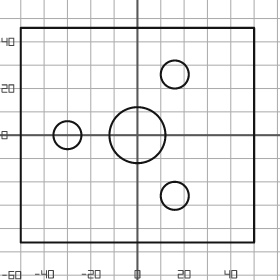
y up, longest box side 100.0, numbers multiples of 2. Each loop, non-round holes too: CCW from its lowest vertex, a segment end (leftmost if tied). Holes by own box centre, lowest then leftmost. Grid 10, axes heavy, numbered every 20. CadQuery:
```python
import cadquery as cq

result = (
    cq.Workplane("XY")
    .moveTo(-50.0, -46.0)
    .lineTo(50.0, -46.0)
    .lineTo(50.0, 46.0)
    .lineTo(-50.0, 46.0)
    .close()
    .moveTo(16.0, -26.0)
    .circle(6.0)
    .moveTo(-30.0, 0.0)
    .circle(6.0)
    .moveTo(0.0, 0.0)
    .circle(12.0)
    .moveTo(16.0, 26.0)
    .circle(6.0)
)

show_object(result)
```